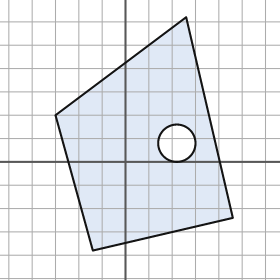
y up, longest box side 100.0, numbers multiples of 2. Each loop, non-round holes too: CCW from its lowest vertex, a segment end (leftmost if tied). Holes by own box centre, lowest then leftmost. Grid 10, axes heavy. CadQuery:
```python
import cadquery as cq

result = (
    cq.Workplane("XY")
    .moveTo(-14.0, -38.0)
    .lineTo(46.0, -24.0)
    .lineTo(26.0, 62.0)
    .lineTo(-30.0, 20.0)
    .close()
    .moveTo(22.0, 8.0)
    .circle(8.0)
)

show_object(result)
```